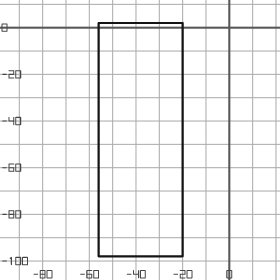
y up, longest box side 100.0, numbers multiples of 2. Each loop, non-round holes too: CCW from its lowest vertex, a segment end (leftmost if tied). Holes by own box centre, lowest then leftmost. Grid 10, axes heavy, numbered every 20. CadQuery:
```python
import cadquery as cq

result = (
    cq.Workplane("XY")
    .moveTo(-56.0, -98.0)
    .lineTo(-20.0, -98.0)
    .lineTo(-20.0, 2.0)
    .lineTo(-56.0, 2.0)
    .close()
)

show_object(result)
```